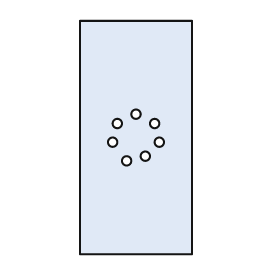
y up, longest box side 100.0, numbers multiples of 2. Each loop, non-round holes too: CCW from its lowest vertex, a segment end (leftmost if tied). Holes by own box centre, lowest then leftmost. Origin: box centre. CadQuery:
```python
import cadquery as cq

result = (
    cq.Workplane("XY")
    .moveTo(-24.0, -50.0)
    .lineTo(24.0, -50.0)
    .lineTo(24.0, 50.0)
    .lineTo(-24.0, 50.0)
    .close()
    .moveTo(-4.0, -10.0)
    .circle(2.0)
    .moveTo(4.0, -8.0)
    .circle(2.0)
    .moveTo(-10.0, -2.0)
    .circle(2.0)
    .moveTo(10.0, -2.0)
    .circle(2.0)
    .moveTo(-8.0, 6.0)
    .circle(2.0)
    .moveTo(8.0, 6.0)
    .circle(2.0)
    .moveTo(0.0, 10.0)
    .circle(2.0)
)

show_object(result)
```